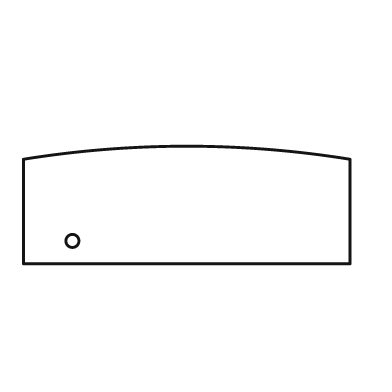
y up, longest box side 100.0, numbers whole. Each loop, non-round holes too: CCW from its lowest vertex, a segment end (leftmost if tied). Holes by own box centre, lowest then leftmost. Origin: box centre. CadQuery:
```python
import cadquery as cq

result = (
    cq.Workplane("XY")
    .moveTo(-50.0, -18.0)
    .lineTo(50.0, -18.0)
    .lineTo(50.0, 14.0)
    .threePointArc((0.0, 18.0), (-50.0, 14.0))
    .close()
    .moveTo(-35.0, -11.0)
    .circle(2.0)
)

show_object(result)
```